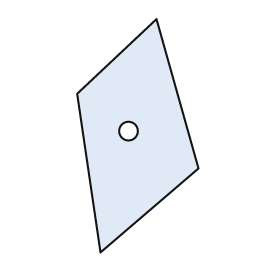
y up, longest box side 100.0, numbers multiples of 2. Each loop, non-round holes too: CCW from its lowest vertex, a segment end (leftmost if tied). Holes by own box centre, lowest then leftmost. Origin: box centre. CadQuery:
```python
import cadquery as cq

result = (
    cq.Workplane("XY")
    .moveTo(-16.0, -50.0)
    .lineTo(26.0, -14.0)
    .lineTo(8.0, 50.0)
    .lineTo(-26.0, 18.0)
    .close()
    .moveTo(-4.0, 2.0)
    .circle(4.0)
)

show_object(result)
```